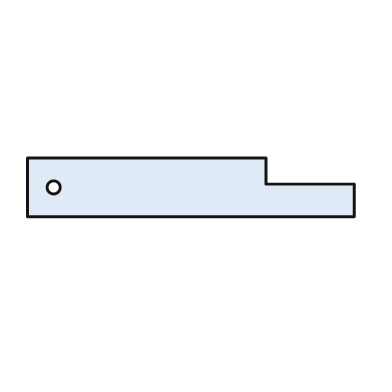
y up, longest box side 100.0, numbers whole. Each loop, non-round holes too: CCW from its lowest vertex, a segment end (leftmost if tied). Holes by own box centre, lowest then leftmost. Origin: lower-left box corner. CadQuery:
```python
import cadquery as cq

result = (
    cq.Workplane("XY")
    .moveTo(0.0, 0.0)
    .lineTo(100.0, 0.0)
    .lineTo(100.0, 10.0)
    .lineTo(73.0, 10.0)
    .lineTo(73.0, 18.0)
    .lineTo(0.0, 18.0)
    .close()
    .moveTo(8.0, 9.0)
    .circle(2.0)
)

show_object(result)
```